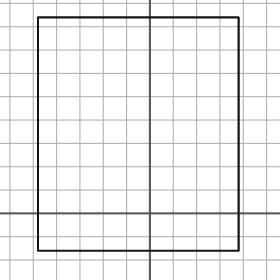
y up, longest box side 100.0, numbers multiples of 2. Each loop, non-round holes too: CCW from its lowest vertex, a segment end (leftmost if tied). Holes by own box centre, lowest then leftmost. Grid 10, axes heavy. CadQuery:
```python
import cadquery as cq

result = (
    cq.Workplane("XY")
    .moveTo(-48.0, -16.0)
    .lineTo(38.0, -16.0)
    .lineTo(38.0, 84.0)
    .lineTo(-48.0, 84.0)
    .close()
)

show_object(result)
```